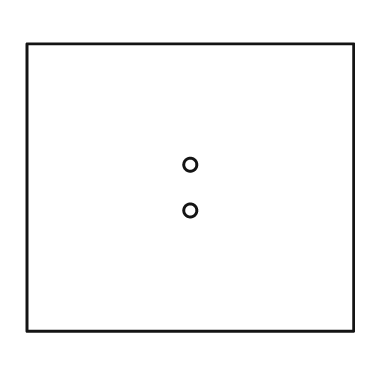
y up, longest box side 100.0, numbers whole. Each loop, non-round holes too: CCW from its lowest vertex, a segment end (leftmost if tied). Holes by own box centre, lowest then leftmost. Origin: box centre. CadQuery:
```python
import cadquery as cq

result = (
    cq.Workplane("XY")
    .moveTo(-50.0, -44.0)
    .lineTo(50.0, -44.0)
    .lineTo(50.0, 44.0)
    .lineTo(-50.0, 44.0)
    .close()
    .moveTo(0.0, -7.0)
    .circle(2.0)
    .moveTo(0.0, 7.0)
    .circle(2.0)
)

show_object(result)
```